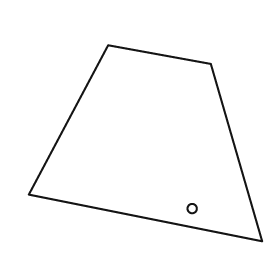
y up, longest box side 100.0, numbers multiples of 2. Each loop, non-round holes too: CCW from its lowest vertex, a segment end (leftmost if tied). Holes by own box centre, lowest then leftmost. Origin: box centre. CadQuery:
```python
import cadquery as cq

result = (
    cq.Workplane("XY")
    .moveTo(50.0, -42.0)
    .lineTo(28.0, 34.0)
    .lineTo(-16.0, 42.0)
    .lineTo(-50.0, -22.0)
    .close()
    .moveTo(20.0, -28.0)
    .circle(2.0)
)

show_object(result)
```